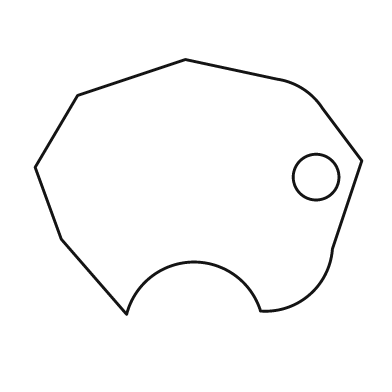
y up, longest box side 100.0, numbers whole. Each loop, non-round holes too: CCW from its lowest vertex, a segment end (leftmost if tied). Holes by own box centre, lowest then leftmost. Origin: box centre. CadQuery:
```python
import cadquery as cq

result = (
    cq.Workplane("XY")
    .moveTo(-22.0, -39.0)
    .threePointArc((-2.0, -23.0), (19.0, -38.0))
    .threePointArc((34.0, -33.0), (41.0, -19.0))
    .lineTo(50.0, 8.0)
    .lineTo(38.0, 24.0)
    .threePointArc((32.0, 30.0), (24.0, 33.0))
    .lineTo(-4.0, 39.0)
    .lineTo(-37.0, 28.0)
    .lineTo(-50.0, 6.0)
    .lineTo(-42.0, -16.0)
    .close()
    .moveTo(36.0, 3.0)
    .circle(7.0)
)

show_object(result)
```